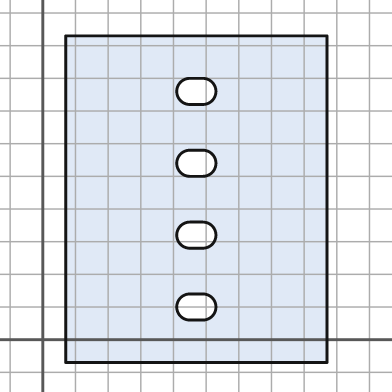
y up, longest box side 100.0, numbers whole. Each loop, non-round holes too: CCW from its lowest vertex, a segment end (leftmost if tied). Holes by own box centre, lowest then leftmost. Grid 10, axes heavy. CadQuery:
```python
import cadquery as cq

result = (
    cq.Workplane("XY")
    .moveTo(7.0, -7.0)
    .lineTo(87.0, -7.0)
    .lineTo(87.0, 93.0)
    .lineTo(7.0, 93.0)
    .close()
    .moveTo(45.0, 6.0)
    .lineTo(49.0, 6.0)
    .threePointArc((53.0, 10.0), (49.0, 14.0))
    .lineTo(45.0, 14.0)
    .threePointArc((41.0, 10.0), (45.0, 6.0))
    .close()
    .moveTo(45.0, 28.0)
    .lineTo(49.0, 28.0)
    .threePointArc((53.0, 32.0), (49.0, 36.0))
    .lineTo(45.0, 36.0)
    .threePointArc((41.0, 32.0), (45.0, 28.0))
    .close()
    .moveTo(45.0, 50.0)
    .lineTo(49.0, 50.0)
    .threePointArc((53.0, 54.0), (49.0, 58.0))
    .lineTo(45.0, 58.0)
    .threePointArc((41.0, 54.0), (45.0, 50.0))
    .close()
    .moveTo(45.0, 72.0)
    .lineTo(49.0, 72.0)
    .threePointArc((53.0, 76.0), (49.0, 80.0))
    .lineTo(45.0, 80.0)
    .threePointArc((41.0, 76.0), (45.0, 72.0))
    .close()
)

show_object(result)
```